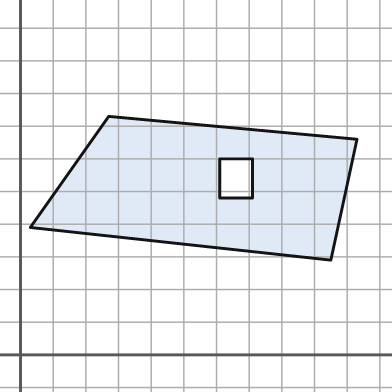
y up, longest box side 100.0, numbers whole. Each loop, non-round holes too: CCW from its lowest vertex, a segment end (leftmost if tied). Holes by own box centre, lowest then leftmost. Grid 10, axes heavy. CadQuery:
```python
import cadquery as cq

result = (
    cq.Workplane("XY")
    .moveTo(95.0, 29.0)
    .lineTo(103.0, 66.0)
    .lineTo(27.0, 73.0)
    .lineTo(3.0, 39.0)
    .close()
    .moveTo(61.0, 48.0)
    .lineTo(71.0, 48.0)
    .lineTo(71.0, 60.0)
    .lineTo(61.0, 60.0)
    .close()
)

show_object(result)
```